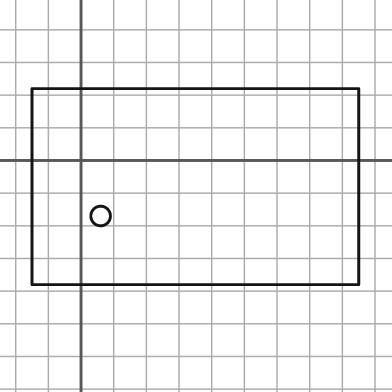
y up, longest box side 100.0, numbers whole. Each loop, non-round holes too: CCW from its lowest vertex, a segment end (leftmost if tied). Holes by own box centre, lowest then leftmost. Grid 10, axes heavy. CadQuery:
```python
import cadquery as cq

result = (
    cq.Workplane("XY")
    .moveTo(-15.0, -38.0)
    .lineTo(85.0, -38.0)
    .lineTo(85.0, 22.0)
    .lineTo(-15.0, 22.0)
    .close()
    .moveTo(6.0, -17.0)
    .circle(3.0)
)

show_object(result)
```